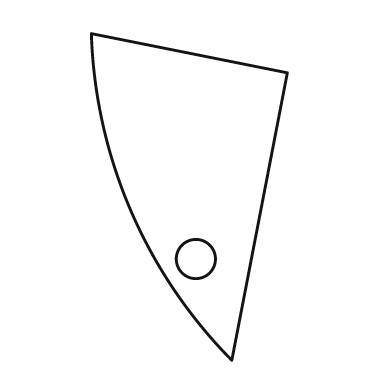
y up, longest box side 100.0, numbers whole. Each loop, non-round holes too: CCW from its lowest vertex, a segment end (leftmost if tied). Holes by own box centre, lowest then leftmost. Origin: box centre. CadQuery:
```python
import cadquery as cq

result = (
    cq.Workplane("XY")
    .moveTo(13.0, -50.0)
    .lineTo(30.0, 38.0)
    .lineTo(-30.0, 50.0)
    .threePointArc((-18.0, -4.0), (13.0, -50.0))
    .close()
    .moveTo(2.0, -19.0)
    .circle(6.0)
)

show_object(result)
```